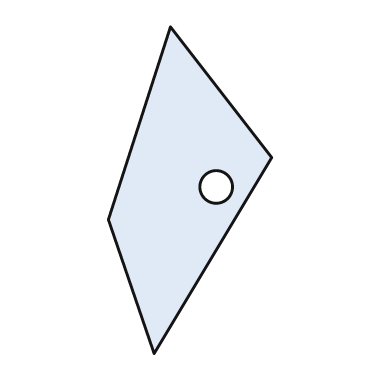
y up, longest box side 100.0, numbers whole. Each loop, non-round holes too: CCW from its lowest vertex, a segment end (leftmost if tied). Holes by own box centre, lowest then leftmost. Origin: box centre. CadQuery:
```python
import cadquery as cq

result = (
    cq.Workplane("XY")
    .moveTo(-11.0, -50.0)
    .lineTo(25.0, 10.0)
    .lineTo(-6.0, 50.0)
    .lineTo(-25.0, -9.0)
    .close()
    .moveTo(8.0, 1.0)
    .circle(5.0)
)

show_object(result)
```